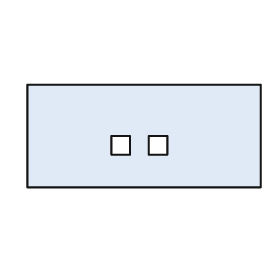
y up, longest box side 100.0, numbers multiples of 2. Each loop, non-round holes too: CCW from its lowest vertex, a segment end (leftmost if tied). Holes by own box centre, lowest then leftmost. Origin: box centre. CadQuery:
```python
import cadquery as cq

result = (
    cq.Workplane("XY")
    .moveTo(-50.0, -22.0)
    .lineTo(50.0, -22.0)
    .lineTo(50.0, 22.0)
    .lineTo(-50.0, 22.0)
    .close()
    .moveTo(-14.0, -8.0)
    .lineTo(-6.0, -8.0)
    .lineTo(-6.0, 0.0)
    .lineTo(-14.0, 0.0)
    .close()
    .moveTo(2.0, -8.0)
    .lineTo(10.0, -8.0)
    .lineTo(10.0, 0.0)
    .lineTo(2.0, 0.0)
    .close()
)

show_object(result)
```